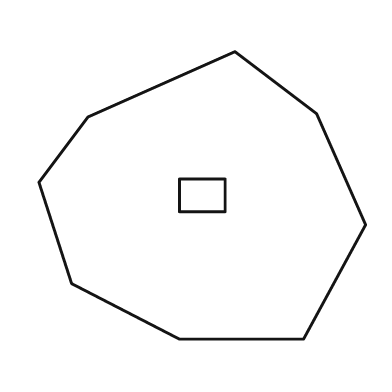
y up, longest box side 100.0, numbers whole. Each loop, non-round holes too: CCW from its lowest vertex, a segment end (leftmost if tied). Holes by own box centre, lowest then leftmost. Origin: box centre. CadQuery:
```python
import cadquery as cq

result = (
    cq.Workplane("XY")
    .moveTo(-7.0, -44.0)
    .lineTo(31.0, -44.0)
    .lineTo(50.0, -9.0)
    .lineTo(35.0, 25.0)
    .lineTo(10.0, 44.0)
    .lineTo(-35.0, 24.0)
    .lineTo(-50.0, 4.0)
    .lineTo(-40.0, -27.0)
    .close()
    .moveTo(-7.0, -5.0)
    .lineTo(7.0, -5.0)
    .lineTo(7.0, 5.0)
    .lineTo(-7.0, 5.0)
    .close()
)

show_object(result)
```